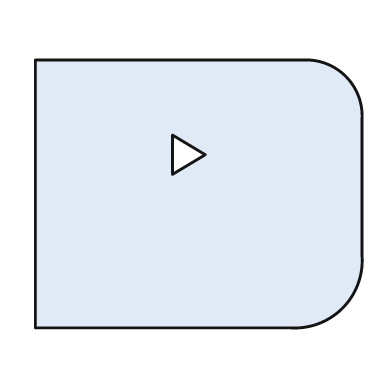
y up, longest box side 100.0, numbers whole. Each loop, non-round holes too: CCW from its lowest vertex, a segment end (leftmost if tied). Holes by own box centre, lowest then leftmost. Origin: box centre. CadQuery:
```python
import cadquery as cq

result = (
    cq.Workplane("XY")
    .moveTo(-50.0, -41.0)
    .lineTo(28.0, -41.0)
    .threePointArc((44.0, -35.0), (50.0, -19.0))
    .lineTo(50.0, 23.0)
    .threePointArc((45.0, 36.0), (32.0, 41.0))
    .lineTo(-50.0, 41.0)
    .close()
    .moveTo(-8.0, 6.0)
    .lineTo(2.0, 12.0)
    .lineTo(-8.0, 18.0)
    .close()
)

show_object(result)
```